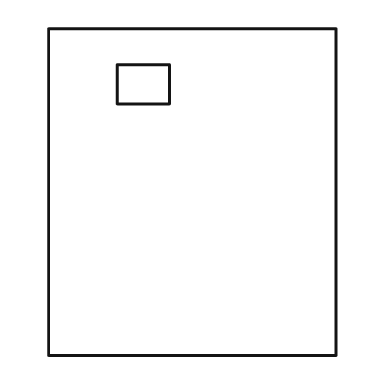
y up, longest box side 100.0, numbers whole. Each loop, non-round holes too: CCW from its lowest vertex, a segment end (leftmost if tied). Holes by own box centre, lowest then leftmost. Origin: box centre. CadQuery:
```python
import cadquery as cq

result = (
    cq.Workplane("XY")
    .moveTo(-44.0, -50.0)
    .lineTo(44.0, -50.0)
    .lineTo(44.0, 50.0)
    .lineTo(-44.0, 50.0)
    .close()
    .moveTo(-23.0, 27.0)
    .lineTo(-7.0, 27.0)
    .lineTo(-7.0, 39.0)
    .lineTo(-23.0, 39.0)
    .close()
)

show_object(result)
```